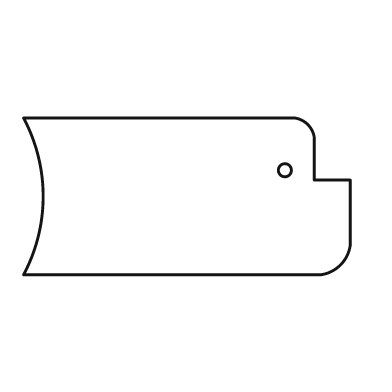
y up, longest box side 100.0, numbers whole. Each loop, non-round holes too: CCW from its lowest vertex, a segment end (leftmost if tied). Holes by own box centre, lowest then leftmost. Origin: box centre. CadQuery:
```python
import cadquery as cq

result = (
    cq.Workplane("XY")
    .moveTo(-50.0, -24.0)
    .lineTo(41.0, -24.0)
    .threePointArc((47.0, -21.0), (50.0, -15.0))
    .lineTo(50.0, 5.0)
    .lineTo(39.0, 5.0)
    .lineTo(39.0, 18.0)
    .threePointArc((37.0, 22.0), (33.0, 24.0))
    .lineTo(-50.0, 24.0)
    .threePointArc((-44.0, 0.0), (-50.0, -24.0))
    .close()
    .moveTo(30.0, 8.0)
    .circle(2.0)
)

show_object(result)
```